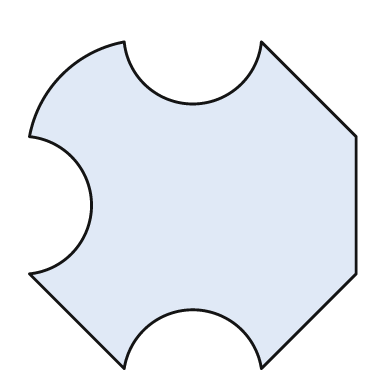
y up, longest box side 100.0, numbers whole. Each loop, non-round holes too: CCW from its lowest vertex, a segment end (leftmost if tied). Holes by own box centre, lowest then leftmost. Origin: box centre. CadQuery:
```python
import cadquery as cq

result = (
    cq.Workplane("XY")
    .moveTo(-21.0, -50.0)
    .threePointArc((0.0, -32.0), (21.0, -50.0))
    .lineTo(50.0, -21.0)
    .lineTo(50.0, 21.0)
    .lineTo(21.0, 50.0)
    .threePointArc((0.0, 31.0), (-21.0, 50.0))
    .threePointArc((-40.0, 40.0), (-50.0, 21.0))
    .threePointArc((-31.0, 0.0), (-50.0, -21.0))
    .close()
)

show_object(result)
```